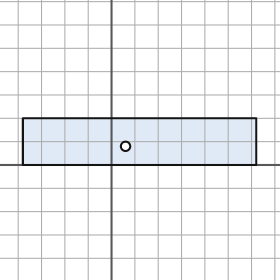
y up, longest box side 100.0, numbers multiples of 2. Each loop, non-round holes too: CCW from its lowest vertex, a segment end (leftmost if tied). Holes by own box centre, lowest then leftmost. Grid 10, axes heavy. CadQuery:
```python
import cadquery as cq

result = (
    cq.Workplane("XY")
    .moveTo(-38.0, 0.0)
    .lineTo(62.0, 0.0)
    .lineTo(62.0, 20.0)
    .lineTo(-38.0, 20.0)
    .close()
    .moveTo(6.0, 8.0)
    .circle(2.0)
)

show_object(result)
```